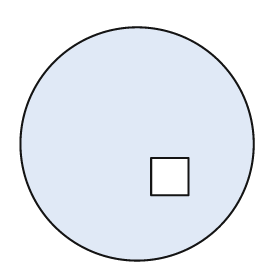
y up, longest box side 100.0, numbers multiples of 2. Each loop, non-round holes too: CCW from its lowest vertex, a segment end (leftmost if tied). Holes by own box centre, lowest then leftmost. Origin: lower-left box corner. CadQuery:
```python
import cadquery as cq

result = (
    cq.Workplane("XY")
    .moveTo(50.0, 50.0)
    .circle(50.0)
    .moveTo(56.0, 28.0)
    .lineTo(72.0, 28.0)
    .lineTo(72.0, 44.0)
    .lineTo(56.0, 44.0)
    .close()
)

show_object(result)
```